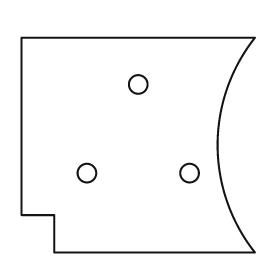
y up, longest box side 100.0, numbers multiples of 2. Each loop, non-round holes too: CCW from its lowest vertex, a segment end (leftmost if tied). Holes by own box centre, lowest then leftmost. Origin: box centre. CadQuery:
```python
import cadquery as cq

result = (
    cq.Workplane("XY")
    .moveTo(-36.0, -46.0)
    .lineTo(50.0, -46.0)
    .threePointArc((34.0, 0.0), (50.0, 46.0))
    .lineTo(-50.0, 46.0)
    .lineTo(-50.0, -30.0)
    .lineTo(-36.0, -30.0)
    .close()
    .moveTo(-22.0, -12.0)
    .circle(4.0)
    .moveTo(22.0, -12.0)
    .circle(4.0)
    .moveTo(0.0, 26.0)
    .circle(4.0)
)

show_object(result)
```